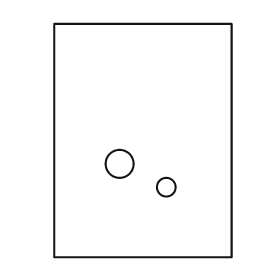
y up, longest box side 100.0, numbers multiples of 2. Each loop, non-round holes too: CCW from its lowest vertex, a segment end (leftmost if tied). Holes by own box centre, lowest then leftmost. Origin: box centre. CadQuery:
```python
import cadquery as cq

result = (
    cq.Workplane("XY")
    .moveTo(-38.0, -50.0)
    .lineTo(38.0, -50.0)
    .lineTo(38.0, 50.0)
    .lineTo(-38.0, 50.0)
    .close()
    .moveTo(10.0, -20.0)
    .circle(4.0)
    .moveTo(-10.0, -10.0)
    .circle(6.0)
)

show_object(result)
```